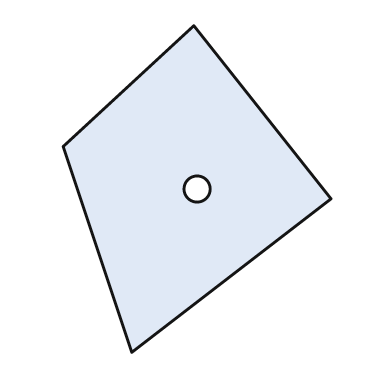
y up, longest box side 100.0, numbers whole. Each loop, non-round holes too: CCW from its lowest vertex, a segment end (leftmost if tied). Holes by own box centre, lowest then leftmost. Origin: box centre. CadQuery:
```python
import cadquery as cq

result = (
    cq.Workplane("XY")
    .moveTo(-20.0, -50.0)
    .lineTo(41.0, -3.0)
    .lineTo(-1.0, 50.0)
    .lineTo(-41.0, 13.0)
    .close()
    .moveTo(0.0, 0.0)
    .circle(4.0)
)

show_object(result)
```